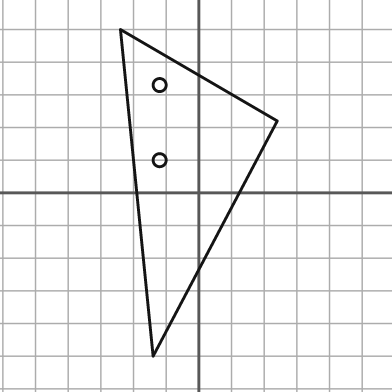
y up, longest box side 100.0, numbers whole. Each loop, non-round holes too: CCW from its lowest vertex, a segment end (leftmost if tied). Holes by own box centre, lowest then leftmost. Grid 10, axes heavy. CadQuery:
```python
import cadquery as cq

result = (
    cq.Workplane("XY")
    .moveTo(-14.0, -50.0)
    .lineTo(24.0, 22.0)
    .lineTo(-24.0, 50.0)
    .close()
    .moveTo(-12.0, 10.0)
    .circle(2.0)
    .moveTo(-12.0, 33.0)
    .circle(2.0)
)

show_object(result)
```